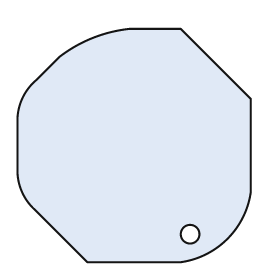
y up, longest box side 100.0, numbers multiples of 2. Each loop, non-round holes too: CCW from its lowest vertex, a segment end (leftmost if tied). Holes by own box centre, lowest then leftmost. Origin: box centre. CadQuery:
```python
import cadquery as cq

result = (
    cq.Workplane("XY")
    .moveTo(-20.0, -50.0)
    .lineTo(20.0, -50.0)
    .threePointArc((40.0, -40.0), (50.0, -20.0))
    .lineTo(50.0, 20.0)
    .lineTo(20.0, 50.0)
    .lineTo(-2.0, 50.0)
    .threePointArc((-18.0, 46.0), (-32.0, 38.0))
    .lineTo(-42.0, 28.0)
    .threePointArc((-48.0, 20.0), (-50.0, 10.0))
    .lineTo(-50.0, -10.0)
    .threePointArc((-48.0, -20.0), (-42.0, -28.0))
    .close()
    .moveTo(24.0, -38.0)
    .circle(4.0)
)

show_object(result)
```